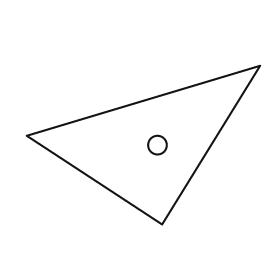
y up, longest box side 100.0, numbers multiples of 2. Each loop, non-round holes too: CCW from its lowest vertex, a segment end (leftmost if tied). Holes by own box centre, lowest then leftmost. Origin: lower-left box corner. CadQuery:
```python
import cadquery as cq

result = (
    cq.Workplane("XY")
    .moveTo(58.0, 0.0)
    .lineTo(100.0, 68.0)
    .lineTo(0.0, 38.0)
    .close()
    .moveTo(56.0, 34.0)
    .circle(4.0)
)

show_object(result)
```